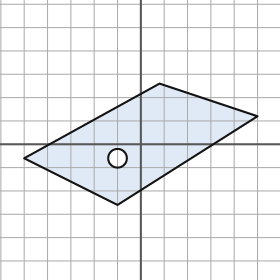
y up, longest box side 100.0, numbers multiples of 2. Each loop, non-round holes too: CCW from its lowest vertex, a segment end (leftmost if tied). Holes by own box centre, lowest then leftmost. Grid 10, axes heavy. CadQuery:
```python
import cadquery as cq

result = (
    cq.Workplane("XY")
    .moveTo(-10.0, -26.0)
    .lineTo(50.0, 12.0)
    .lineTo(8.0, 26.0)
    .lineTo(-50.0, -6.0)
    .close()
    .moveTo(-10.0, -6.0)
    .circle(4.0)
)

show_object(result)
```